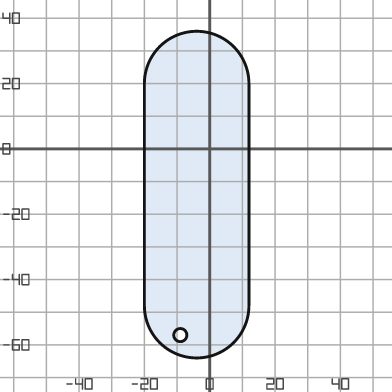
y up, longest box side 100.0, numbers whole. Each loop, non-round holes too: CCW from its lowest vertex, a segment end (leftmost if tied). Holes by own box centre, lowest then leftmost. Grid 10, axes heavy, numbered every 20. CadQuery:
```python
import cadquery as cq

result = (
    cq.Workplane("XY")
    .moveTo(-20.0, -48.0)
    .threePointArc((-4.0, -64.0), (12.0, -48.0))
    .lineTo(12.0, 20.0)
    .threePointArc((-4.0, 36.0), (-20.0, 20.0))
    .close()
    .moveTo(-9.0, -57.0)
    .circle(2.0)
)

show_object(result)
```